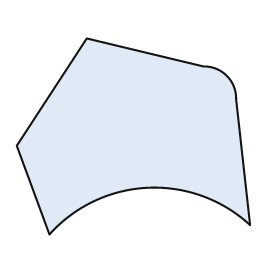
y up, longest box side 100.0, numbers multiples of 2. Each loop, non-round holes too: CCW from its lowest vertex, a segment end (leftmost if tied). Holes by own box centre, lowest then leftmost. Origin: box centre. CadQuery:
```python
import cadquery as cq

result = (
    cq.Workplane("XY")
    .moveTo(-36.0, -42.0)
    .threePointArc((6.0, -22.0), (50.0, -38.0))
    .lineTo(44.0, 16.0)
    .threePointArc((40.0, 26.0), (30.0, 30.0))
    .lineTo(-20.0, 42.0)
    .lineTo(-50.0, -4.0)
    .close()
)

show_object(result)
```